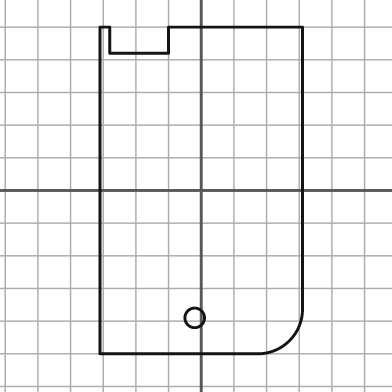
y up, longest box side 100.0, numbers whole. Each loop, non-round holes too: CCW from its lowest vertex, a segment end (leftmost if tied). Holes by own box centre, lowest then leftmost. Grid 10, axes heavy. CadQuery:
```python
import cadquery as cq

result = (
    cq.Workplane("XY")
    .moveTo(-31.0, -50.0)
    .lineTo(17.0, -50.0)
    .threePointArc((27.0, -46.0), (31.0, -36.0))
    .lineTo(31.0, 50.0)
    .lineTo(-10.0, 50.0)
    .lineTo(-10.0, 42.0)
    .lineTo(-28.0, 42.0)
    .lineTo(-28.0, 50.0)
    .lineTo(-31.0, 50.0)
    .close()
    .moveTo(-2.0, -39.0)
    .circle(3.0)
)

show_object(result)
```